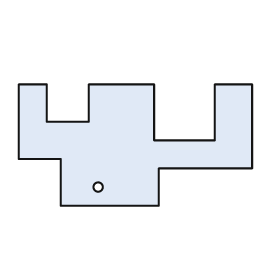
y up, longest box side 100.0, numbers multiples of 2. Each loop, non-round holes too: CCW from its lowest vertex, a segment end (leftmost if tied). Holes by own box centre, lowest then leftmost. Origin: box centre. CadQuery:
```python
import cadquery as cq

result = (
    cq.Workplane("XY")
    .moveTo(-32.0, -26.0)
    .lineTo(10.0, -26.0)
    .lineTo(10.0, -10.0)
    .lineTo(50.0, -10.0)
    .lineTo(50.0, 26.0)
    .lineTo(34.0, 26.0)
    .lineTo(34.0, 2.0)
    .lineTo(8.0, 2.0)
    .lineTo(8.0, 26.0)
    .lineTo(-20.0, 26.0)
    .lineTo(-20.0, 10.0)
    .lineTo(-38.0, 10.0)
    .lineTo(-38.0, 26.0)
    .lineTo(-50.0, 26.0)
    .lineTo(-50.0, -6.0)
    .lineTo(-32.0, -6.0)
    .close()
    .moveTo(-16.0, -18.0)
    .circle(2.0)
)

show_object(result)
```